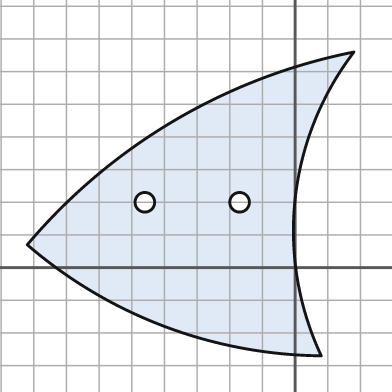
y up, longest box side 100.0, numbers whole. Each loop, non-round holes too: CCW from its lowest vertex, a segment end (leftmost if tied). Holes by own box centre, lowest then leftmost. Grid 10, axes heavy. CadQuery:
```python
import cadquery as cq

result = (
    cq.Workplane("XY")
    .moveTo(8.0, -27.0)
    .threePointArc((0.0, 21.0), (18.0, 66.0))
    .threePointArc((-37.0, 45.0), (-82.0, 7.0))
    .threePointArc((-40.0, -18.0), (8.0, -27.0))
    .close()
    .moveTo(-46.0, 20.0)
    .circle(3.0)
    .moveTo(-17.0, 20.0)
    .circle(3.0)
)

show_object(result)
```